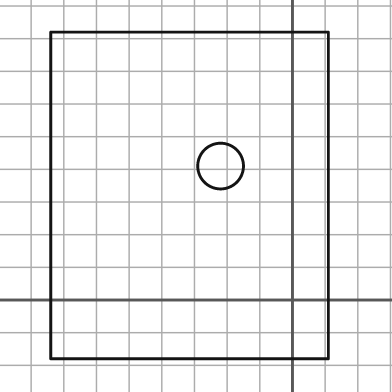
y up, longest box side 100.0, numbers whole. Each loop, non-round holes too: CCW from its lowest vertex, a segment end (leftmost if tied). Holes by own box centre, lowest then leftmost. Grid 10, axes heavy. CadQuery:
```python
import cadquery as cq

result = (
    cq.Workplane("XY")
    .moveTo(-74.0, -18.0)
    .lineTo(11.0, -18.0)
    .lineTo(11.0, 82.0)
    .lineTo(-74.0, 82.0)
    .close()
    .moveTo(-22.0, 41.0)
    .circle(7.0)
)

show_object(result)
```